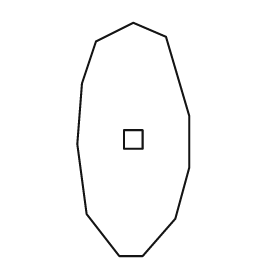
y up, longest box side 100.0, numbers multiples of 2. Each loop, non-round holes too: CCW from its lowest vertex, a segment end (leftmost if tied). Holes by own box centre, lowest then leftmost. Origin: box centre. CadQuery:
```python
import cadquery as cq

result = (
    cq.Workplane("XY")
    .moveTo(-6.0, -50.0)
    .lineTo(4.0, -50.0)
    .lineTo(18.0, -34.0)
    .lineTo(24.0, -12.0)
    .lineTo(24.0, 10.0)
    .lineTo(14.0, 44.0)
    .lineTo(0.0, 50.0)
    .lineTo(-16.0, 42.0)
    .lineTo(-22.0, 24.0)
    .lineTo(-24.0, -2.0)
    .lineTo(-20.0, -32.0)
    .close()
    .moveTo(-4.0, -4.0)
    .lineTo(4.0, -4.0)
    .lineTo(4.0, 4.0)
    .lineTo(-4.0, 4.0)
    .close()
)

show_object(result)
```